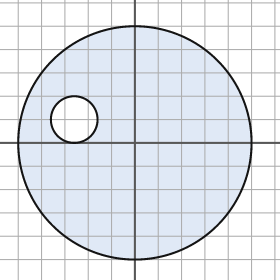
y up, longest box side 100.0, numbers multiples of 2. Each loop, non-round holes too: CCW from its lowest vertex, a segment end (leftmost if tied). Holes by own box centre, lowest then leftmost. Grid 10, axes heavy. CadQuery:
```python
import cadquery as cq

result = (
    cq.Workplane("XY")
    .moveTo(0.0, 0.0)
    .circle(50.0)
    .moveTo(-26.0, 10.0)
    .circle(10.0)
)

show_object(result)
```